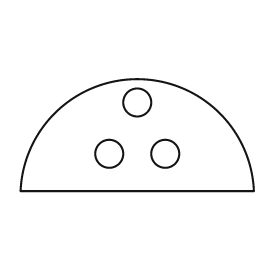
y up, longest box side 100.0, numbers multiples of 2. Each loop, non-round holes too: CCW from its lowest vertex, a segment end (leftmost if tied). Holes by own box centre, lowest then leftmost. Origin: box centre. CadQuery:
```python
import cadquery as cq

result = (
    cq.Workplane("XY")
    .moveTo(-50.0, -24.0)
    .lineTo(50.0, -24.0)
    .threePointArc((0.0, 24.0), (-50.0, -24.0))
    .close()
    .moveTo(-12.0, -8.0)
    .circle(6.0)
    .moveTo(12.0, -8.0)
    .circle(6.0)
    .moveTo(0.0, 14.0)
    .circle(6.0)
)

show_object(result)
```